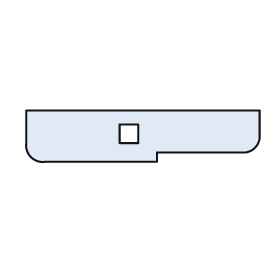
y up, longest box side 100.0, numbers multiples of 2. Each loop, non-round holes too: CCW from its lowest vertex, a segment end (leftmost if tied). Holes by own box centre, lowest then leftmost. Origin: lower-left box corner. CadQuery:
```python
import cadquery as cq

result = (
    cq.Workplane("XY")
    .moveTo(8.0, 0.0)
    .lineTo(56.0, 0.0)
    .lineTo(56.0, 4.0)
    .lineTo(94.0, 4.0)
    .threePointArc((98.0, 6.0), (100.0, 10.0))
    .lineTo(100.0, 22.0)
    .lineTo(0.0, 22.0)
    .lineTo(0.0, 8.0)
    .threePointArc((2.0, 2.0), (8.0, 0.0))
    .close()
    .moveTo(40.0, 8.0)
    .lineTo(48.0, 8.0)
    .lineTo(48.0, 16.0)
    .lineTo(40.0, 16.0)
    .close()
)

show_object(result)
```